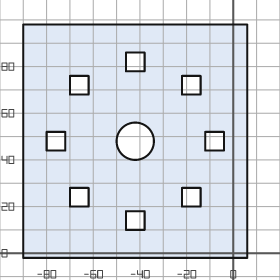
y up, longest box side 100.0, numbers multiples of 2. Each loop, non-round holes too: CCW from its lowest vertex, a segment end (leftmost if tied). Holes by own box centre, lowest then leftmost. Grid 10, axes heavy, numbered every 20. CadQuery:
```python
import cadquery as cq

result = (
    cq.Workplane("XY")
    .moveTo(-90.0, -2.0)
    .lineTo(6.0, -2.0)
    .lineTo(6.0, 98.0)
    .lineTo(-90.0, 98.0)
    .close()
    .moveTo(-46.0, 10.0)
    .lineTo(-38.0, 10.0)
    .lineTo(-38.0, 18.0)
    .lineTo(-46.0, 18.0)
    .close()
    .moveTo(-70.0, 20.0)
    .lineTo(-62.0, 20.0)
    .lineTo(-62.0, 28.0)
    .lineTo(-70.0, 28.0)
    .close()
    .moveTo(-22.0, 20.0)
    .lineTo(-14.0, 20.0)
    .lineTo(-14.0, 28.0)
    .lineTo(-22.0, 28.0)
    .close()
    .moveTo(-80.0, 44.0)
    .lineTo(-72.0, 44.0)
    .lineTo(-72.0, 52.0)
    .lineTo(-80.0, 52.0)
    .close()
    .moveTo(-42.0, 48.0)
    .circle(8.0)
    .moveTo(-12.0, 44.0)
    .lineTo(-4.0, 44.0)
    .lineTo(-4.0, 52.0)
    .lineTo(-12.0, 52.0)
    .close()
    .moveTo(-70.0, 68.0)
    .lineTo(-62.0, 68.0)
    .lineTo(-62.0, 76.0)
    .lineTo(-70.0, 76.0)
    .close()
    .moveTo(-22.0, 68.0)
    .lineTo(-14.0, 68.0)
    .lineTo(-14.0, 76.0)
    .lineTo(-22.0, 76.0)
    .close()
    .moveTo(-46.0, 78.0)
    .lineTo(-38.0, 78.0)
    .lineTo(-38.0, 86.0)
    .lineTo(-46.0, 86.0)
    .close()
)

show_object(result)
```